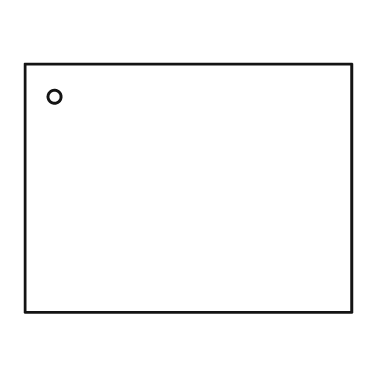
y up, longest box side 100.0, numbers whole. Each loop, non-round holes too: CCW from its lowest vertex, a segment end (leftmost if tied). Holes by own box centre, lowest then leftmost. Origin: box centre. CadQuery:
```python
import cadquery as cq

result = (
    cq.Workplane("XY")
    .moveTo(-50.0, -38.0)
    .lineTo(50.0, -38.0)
    .lineTo(50.0, 38.0)
    .lineTo(-50.0, 38.0)
    .close()
    .moveTo(-41.0, 28.0)
    .circle(2.0)
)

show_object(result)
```